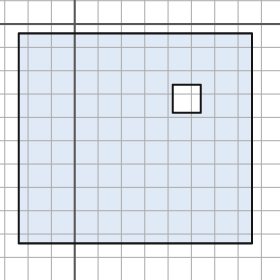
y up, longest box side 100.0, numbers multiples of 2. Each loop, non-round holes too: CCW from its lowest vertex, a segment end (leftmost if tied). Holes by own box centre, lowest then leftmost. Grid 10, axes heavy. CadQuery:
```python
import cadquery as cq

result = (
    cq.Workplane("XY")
    .moveTo(-24.0, -94.0)
    .lineTo(76.0, -94.0)
    .lineTo(76.0, -4.0)
    .lineTo(-24.0, -4.0)
    .close()
    .moveTo(42.0, -38.0)
    .lineTo(54.0, -38.0)
    .lineTo(54.0, -26.0)
    .lineTo(42.0, -26.0)
    .close()
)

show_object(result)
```